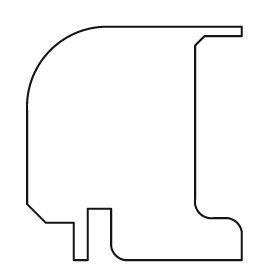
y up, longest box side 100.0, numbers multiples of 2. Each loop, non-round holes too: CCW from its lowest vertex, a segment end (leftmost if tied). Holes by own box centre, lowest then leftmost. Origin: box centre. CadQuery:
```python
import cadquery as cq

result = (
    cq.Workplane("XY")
    .moveTo(-26.0, -50.0)
    .lineTo(-20.0, -50.0)
    .lineTo(-20.0, -28.0)
    .lineTo(-10.0, -28.0)
    .lineTo(-10.0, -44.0)
    .threePointArc((-8.0, -48.0), (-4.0, -50.0))
    .lineTo(46.0, -50.0)
    .lineTo(46.0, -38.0)
    .threePointArc((44.0, -34.0), (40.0, -32.0))
    .lineTo(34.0, -32.0)
    .threePointArc((28.0, -30.0), (26.0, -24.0))
    .lineTo(26.0, 42.0)
    .lineTo(30.0, 46.0)
    .lineTo(46.0, 46.0)
    .lineTo(46.0, 50.0)
    .lineTo(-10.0, 50.0)
    .threePointArc((-36.0, 40.0), (-46.0, 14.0))
    .lineTo(-46.0, -26.0)
    .lineTo(-38.0, -34.0)
    .lineTo(-26.0, -34.0)
    .close()
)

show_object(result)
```